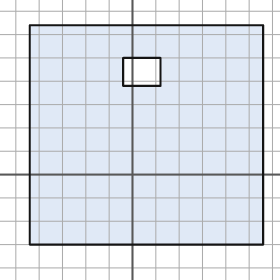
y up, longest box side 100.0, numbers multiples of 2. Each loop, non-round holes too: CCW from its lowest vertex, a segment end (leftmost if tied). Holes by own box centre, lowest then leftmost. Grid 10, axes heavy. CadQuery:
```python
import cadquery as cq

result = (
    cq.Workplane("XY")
    .moveTo(-44.0, -30.0)
    .lineTo(56.0, -30.0)
    .lineTo(56.0, 64.0)
    .lineTo(-44.0, 64.0)
    .close()
    .moveTo(-4.0, 38.0)
    .lineTo(12.0, 38.0)
    .lineTo(12.0, 50.0)
    .lineTo(-4.0, 50.0)
    .close()
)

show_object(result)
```